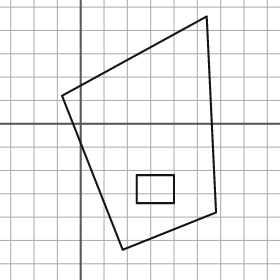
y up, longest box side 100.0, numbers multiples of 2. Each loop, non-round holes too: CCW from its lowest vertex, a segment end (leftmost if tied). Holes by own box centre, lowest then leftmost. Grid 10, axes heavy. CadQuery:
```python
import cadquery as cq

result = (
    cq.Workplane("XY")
    .moveTo(18.0, -54.0)
    .lineTo(58.0, -38.0)
    .lineTo(54.0, 46.0)
    .lineTo(-8.0, 12.0)
    .close()
    .moveTo(24.0, -34.0)
    .lineTo(40.0, -34.0)
    .lineTo(40.0, -22.0)
    .lineTo(24.0, -22.0)
    .close()
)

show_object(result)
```